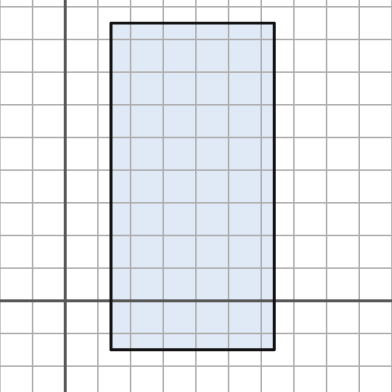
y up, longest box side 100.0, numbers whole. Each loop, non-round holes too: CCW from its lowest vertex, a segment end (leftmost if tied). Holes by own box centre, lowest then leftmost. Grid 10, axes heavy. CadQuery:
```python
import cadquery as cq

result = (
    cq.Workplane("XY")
    .moveTo(14.0, -15.0)
    .lineTo(64.0, -15.0)
    .lineTo(64.0, 85.0)
    .lineTo(14.0, 85.0)
    .close()
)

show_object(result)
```